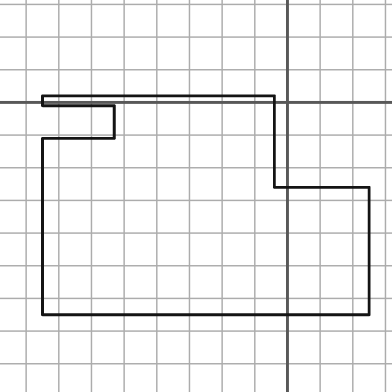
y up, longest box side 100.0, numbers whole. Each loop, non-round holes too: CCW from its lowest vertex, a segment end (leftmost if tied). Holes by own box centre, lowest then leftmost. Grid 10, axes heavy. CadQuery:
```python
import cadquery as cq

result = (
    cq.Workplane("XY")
    .moveTo(-75.0, -65.0)
    .lineTo(25.0, -65.0)
    .lineTo(25.0, -26.0)
    .lineTo(-4.0, -26.0)
    .lineTo(-4.0, 2.0)
    .lineTo(-75.0, 2.0)
    .lineTo(-75.0, -1.0)
    .lineTo(-53.0, -1.0)
    .lineTo(-53.0, -11.0)
    .lineTo(-75.0, -11.0)
    .close()
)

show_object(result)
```